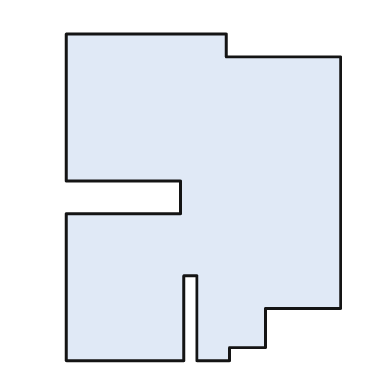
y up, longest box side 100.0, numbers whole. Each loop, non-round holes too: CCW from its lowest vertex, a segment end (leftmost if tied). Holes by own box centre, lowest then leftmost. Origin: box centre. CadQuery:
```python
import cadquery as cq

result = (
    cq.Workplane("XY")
    .moveTo(-42.0, -50.0)
    .lineTo(-6.0, -50.0)
    .lineTo(-6.0, -24.0)
    .lineTo(-2.0, -24.0)
    .lineTo(-2.0, -50.0)
    .lineTo(8.0, -50.0)
    .lineTo(8.0, -46.0)
    .lineTo(19.0, -46.0)
    .lineTo(19.0, -34.0)
    .lineTo(42.0, -34.0)
    .lineTo(42.0, 43.0)
    .lineTo(7.0, 43.0)
    .lineTo(7.0, 50.0)
    .lineTo(-42.0, 50.0)
    .lineTo(-42.0, 5.0)
    .lineTo(-7.0, 5.0)
    .lineTo(-7.0, -5.0)
    .lineTo(-42.0, -5.0)
    .close()
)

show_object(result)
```